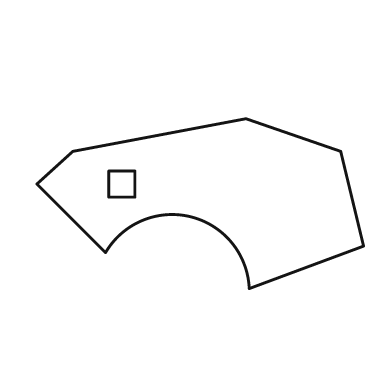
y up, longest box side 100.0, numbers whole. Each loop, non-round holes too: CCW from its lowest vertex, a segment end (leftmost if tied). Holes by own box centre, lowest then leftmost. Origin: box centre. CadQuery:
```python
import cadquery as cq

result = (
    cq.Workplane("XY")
    .moveTo(15.0, -26.0)
    .lineTo(50.0, -13.0)
    .lineTo(43.0, 16.0)
    .lineTo(14.0, 26.0)
    .lineTo(-39.0, 16.0)
    .lineTo(-50.0, 6.0)
    .lineTo(-29.0, -15.0)
    .threePointArc((-3.0, -4.0), (15.0, -26.0))
    .close()
    .moveTo(-28.0, 2.0)
    .lineTo(-20.0, 2.0)
    .lineTo(-20.0, 10.0)
    .lineTo(-28.0, 10.0)
    .close()
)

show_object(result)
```